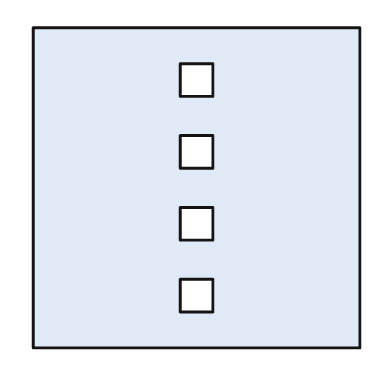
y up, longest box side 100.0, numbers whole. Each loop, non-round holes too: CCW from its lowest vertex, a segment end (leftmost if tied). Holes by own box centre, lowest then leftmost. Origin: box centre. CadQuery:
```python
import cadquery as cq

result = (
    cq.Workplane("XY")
    .moveTo(-50.0, -49.0)
    .lineTo(50.0, -49.0)
    .lineTo(50.0, 49.0)
    .lineTo(-50.0, 49.0)
    .close()
    .moveTo(-5.0, -38.0)
    .lineTo(5.0, -38.0)
    .lineTo(5.0, -28.0)
    .lineTo(-5.0, -28.0)
    .close()
    .moveTo(-5.0, -16.0)
    .lineTo(5.0, -16.0)
    .lineTo(5.0, -6.0)
    .lineTo(-5.0, -6.0)
    .close()
    .moveTo(-5.0, 6.0)
    .lineTo(5.0, 6.0)
    .lineTo(5.0, 16.0)
    .lineTo(-5.0, 16.0)
    .close()
    .moveTo(-5.0, 28.0)
    .lineTo(5.0, 28.0)
    .lineTo(5.0, 38.0)
    .lineTo(-5.0, 38.0)
    .close()
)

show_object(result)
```